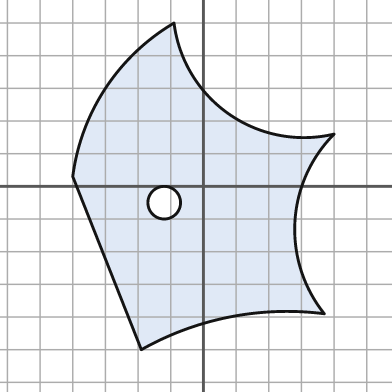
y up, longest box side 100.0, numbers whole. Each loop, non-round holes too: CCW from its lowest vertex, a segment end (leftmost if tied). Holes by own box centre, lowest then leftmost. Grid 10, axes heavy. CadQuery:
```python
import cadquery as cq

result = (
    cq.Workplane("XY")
    .moveTo(-19.0, -50.0)
    .threePointArc((8.0, -40.0), (37.0, -39.0))
    .threePointArc((28.0, -11.0), (40.0, 16.0))
    .threePointArc((8.0, 22.0), (-9.0, 50.0))
    .threePointArc((-30.0, 30.0), (-40.0, 3.0))
    .close()
    .moveTo(-12.0, -5.0)
    .circle(5.0)
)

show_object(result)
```